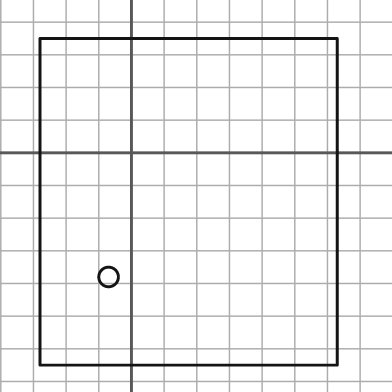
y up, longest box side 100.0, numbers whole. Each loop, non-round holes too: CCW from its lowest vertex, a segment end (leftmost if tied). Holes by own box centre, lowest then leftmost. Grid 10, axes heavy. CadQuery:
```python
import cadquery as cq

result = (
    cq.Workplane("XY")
    .moveTo(-28.0, -65.0)
    .lineTo(63.0, -65.0)
    .lineTo(63.0, 35.0)
    .lineTo(-28.0, 35.0)
    .close()
    .moveTo(-7.0, -38.0)
    .circle(3.0)
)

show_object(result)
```